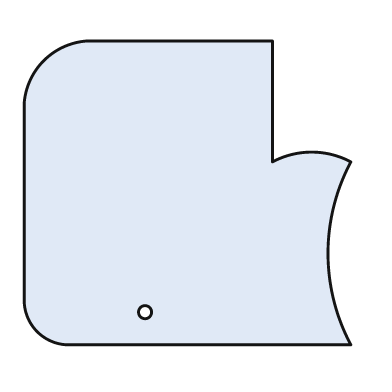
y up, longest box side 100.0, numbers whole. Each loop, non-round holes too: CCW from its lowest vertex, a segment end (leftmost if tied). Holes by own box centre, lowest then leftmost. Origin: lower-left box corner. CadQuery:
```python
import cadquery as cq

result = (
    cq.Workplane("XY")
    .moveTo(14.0, 0.0)
    .lineTo(100.0, 0.0)
    .threePointArc((93.0, 28.0), (100.0, 56.0))
    .threePointArc((88.0, 59.0), (76.0, 56.0))
    .lineTo(76.0, 93.0)
    .lineTo(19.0, 93.0)
    .threePointArc((6.0, 87.0), (0.0, 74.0))
    .lineTo(0.0, 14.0)
    .threePointArc((4.0, 4.0), (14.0, 0.0))
    .close()
    .moveTo(37.0, 10.0)
    .circle(2.0)
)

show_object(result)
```